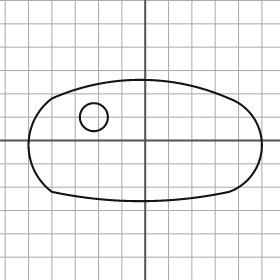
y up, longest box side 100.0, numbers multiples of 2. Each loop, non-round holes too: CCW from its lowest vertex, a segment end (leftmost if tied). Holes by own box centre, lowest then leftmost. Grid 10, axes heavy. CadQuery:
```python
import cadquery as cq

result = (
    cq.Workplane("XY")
    .moveTo(-40.0, -22.0)
    .threePointArc((-2.0, -26.0), (36.0, -22.0))
    .threePointArc((50.0, -2.0), (36.0, 18.0))
    .threePointArc((-2.0, 26.0), (-40.0, 18.0))
    .threePointArc((-50.0, -2.0), (-40.0, -22.0))
    .close()
    .moveTo(-22.0, 10.0)
    .circle(6.0)
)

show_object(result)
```